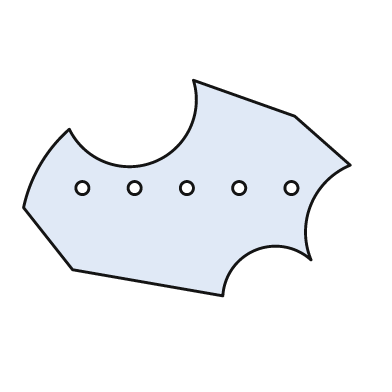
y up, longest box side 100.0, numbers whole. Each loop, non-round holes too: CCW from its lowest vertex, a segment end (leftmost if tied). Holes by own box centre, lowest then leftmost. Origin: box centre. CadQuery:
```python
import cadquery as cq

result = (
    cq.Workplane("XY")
    .moveTo(11.0, -33.0)
    .threePointArc((21.0, -19.0), (38.0, -22.0))
    .threePointArc((38.0, -5.0), (50.0, 7.0))
    .lineTo(33.0, 22.0)
    .lineTo(2.0, 33.0)
    .threePointArc((-10.0, 8.0), (-36.0, 18.0))
    .threePointArc((-45.0, 7.0), (-50.0, -6.0))
    .lineTo(-35.0, -25.0)
    .close()
    .moveTo(-32.0, 0.0)
    .circle(2.0)
    .moveTo(-16.0, 0.0)
    .circle(2.0)
    .moveTo(0.0, 0.0)
    .circle(2.0)
    .moveTo(16.0, 0.0)
    .circle(2.0)
    .moveTo(32.0, 0.0)
    .circle(2.0)
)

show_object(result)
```